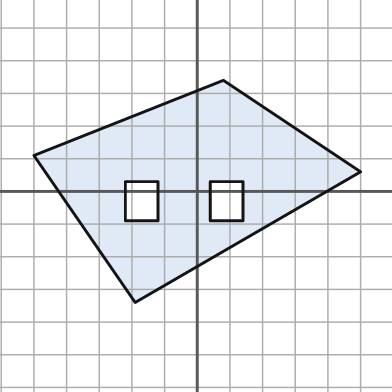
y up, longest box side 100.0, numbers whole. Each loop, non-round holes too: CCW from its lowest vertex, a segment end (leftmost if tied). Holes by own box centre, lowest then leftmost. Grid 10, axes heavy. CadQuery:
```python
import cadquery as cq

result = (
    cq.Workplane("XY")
    .moveTo(-19.0, -34.0)
    .lineTo(50.0, 6.0)
    .lineTo(8.0, 34.0)
    .lineTo(-50.0, 11.0)
    .close()
    .moveTo(-22.0, -9.0)
    .lineTo(-12.0, -9.0)
    .lineTo(-12.0, 3.0)
    .lineTo(-22.0, 3.0)
    .close()
    .moveTo(4.0, -9.0)
    .lineTo(14.0, -9.0)
    .lineTo(14.0, 3.0)
    .lineTo(4.0, 3.0)
    .close()
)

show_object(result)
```